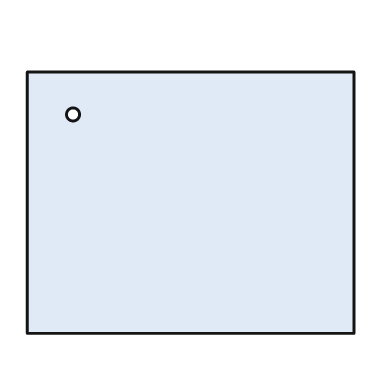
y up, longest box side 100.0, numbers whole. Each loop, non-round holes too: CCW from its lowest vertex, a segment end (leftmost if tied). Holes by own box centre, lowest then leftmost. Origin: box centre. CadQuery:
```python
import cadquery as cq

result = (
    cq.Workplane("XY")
    .moveTo(-50.0, -40.0)
    .lineTo(50.0, -40.0)
    .lineTo(50.0, 40.0)
    .lineTo(-50.0, 40.0)
    .close()
    .moveTo(-36.0, 27.0)
    .circle(2.0)
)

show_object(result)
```